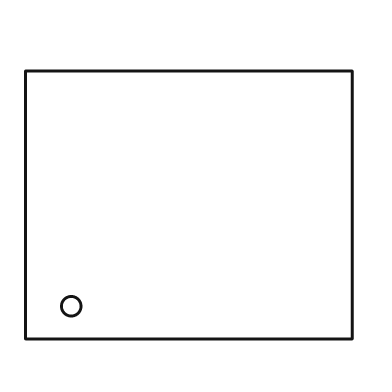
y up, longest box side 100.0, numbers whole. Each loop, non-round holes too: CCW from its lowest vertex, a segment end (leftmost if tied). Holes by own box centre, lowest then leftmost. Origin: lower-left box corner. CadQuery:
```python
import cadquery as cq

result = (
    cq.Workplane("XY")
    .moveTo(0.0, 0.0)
    .lineTo(100.0, 0.0)
    .lineTo(100.0, 82.0)
    .lineTo(0.0, 82.0)
    .close()
    .moveTo(14.0, 10.0)
    .circle(3.0)
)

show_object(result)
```